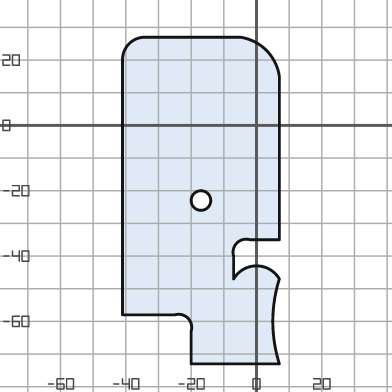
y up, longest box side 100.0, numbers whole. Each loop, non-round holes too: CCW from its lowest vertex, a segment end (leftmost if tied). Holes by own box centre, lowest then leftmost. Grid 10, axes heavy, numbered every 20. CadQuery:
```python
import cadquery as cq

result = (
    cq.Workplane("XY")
    .moveTo(-20.0, -73.0)
    .lineTo(7.0, -73.0)
    .threePointArc((5.0, -60.0), (7.0, -47.0))
    .threePointArc((0.0, -43.0), (-7.0, -47.0))
    .lineTo(-7.0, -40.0)
    .threePointArc((-6.0, -36.0), (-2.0, -35.0))
    .lineTo(7.0, -35.0)
    .lineTo(7.0, 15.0)
    .threePointArc((3.0, 23.0), (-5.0, 27.0))
    .lineTo(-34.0, 27.0)
    .threePointArc((-39.0, 25.0), (-41.0, 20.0))
    .lineTo(-41.0, -58.0)
    .lineTo(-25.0, -58.0)
    .threePointArc((-21.0, -59.0), (-20.0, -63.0))
    .close()
    .moveTo(-17.0, -23.0)
    .circle(3.0)
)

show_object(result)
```